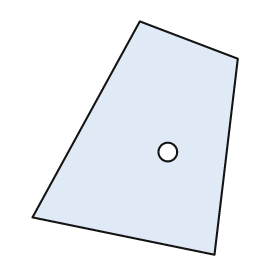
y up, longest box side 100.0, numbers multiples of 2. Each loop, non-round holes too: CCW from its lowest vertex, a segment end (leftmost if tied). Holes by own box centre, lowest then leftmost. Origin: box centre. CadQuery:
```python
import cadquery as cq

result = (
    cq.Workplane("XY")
    .moveTo(34.0, -50.0)
    .lineTo(44.0, 34.0)
    .lineTo(2.0, 50.0)
    .lineTo(-44.0, -34.0)
    .close()
    .moveTo(14.0, -6.0)
    .circle(4.0)
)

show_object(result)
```